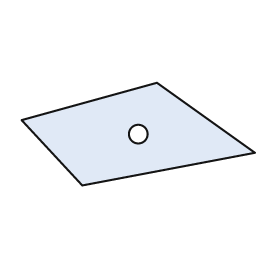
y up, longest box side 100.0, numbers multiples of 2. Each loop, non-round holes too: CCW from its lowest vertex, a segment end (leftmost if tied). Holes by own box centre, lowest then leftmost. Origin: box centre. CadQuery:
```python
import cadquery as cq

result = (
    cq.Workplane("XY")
    .moveTo(-24.0, -22.0)
    .lineTo(50.0, -8.0)
    .lineTo(8.0, 22.0)
    .lineTo(-50.0, 6.0)
    .close()
    .moveTo(0.0, 0.0)
    .circle(4.0)
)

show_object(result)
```